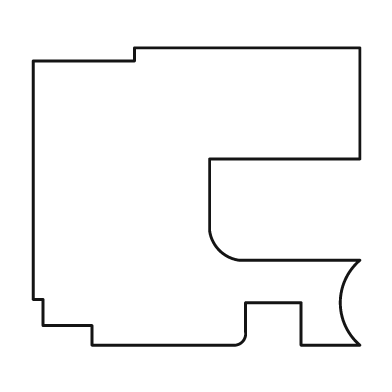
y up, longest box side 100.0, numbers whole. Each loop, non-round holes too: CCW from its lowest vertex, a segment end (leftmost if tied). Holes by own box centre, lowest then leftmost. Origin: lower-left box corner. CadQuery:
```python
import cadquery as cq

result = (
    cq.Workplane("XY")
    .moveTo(18.0, 0.0)
    .lineTo(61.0, 0.0)
    .threePointArc((64.0, 1.0), (65.0, 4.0))
    .lineTo(65.0, 13.0)
    .lineTo(82.0, 13.0)
    .lineTo(82.0, 0.0)
    .lineTo(100.0, 0.0)
    .threePointArc((94.0, 13.0), (100.0, 26.0))
    .lineTo(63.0, 26.0)
    .threePointArc((57.0, 29.0), (54.0, 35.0))
    .lineTo(54.0, 57.0)
    .lineTo(100.0, 57.0)
    .lineTo(100.0, 91.0)
    .lineTo(31.0, 91.0)
    .lineTo(31.0, 87.0)
    .lineTo(0.0, 87.0)
    .lineTo(0.0, 14.0)
    .lineTo(3.0, 14.0)
    .lineTo(3.0, 6.0)
    .lineTo(18.0, 6.0)
    .close()
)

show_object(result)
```